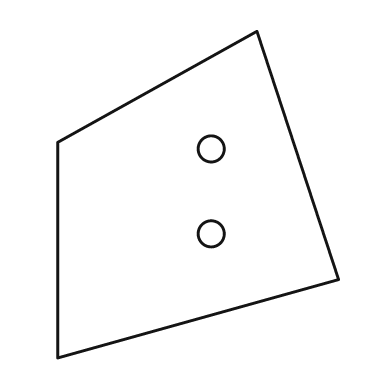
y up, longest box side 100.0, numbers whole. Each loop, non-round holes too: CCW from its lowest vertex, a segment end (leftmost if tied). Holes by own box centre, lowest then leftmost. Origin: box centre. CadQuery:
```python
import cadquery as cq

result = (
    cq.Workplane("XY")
    .moveTo(-43.0, -50.0)
    .lineTo(43.0, -26.0)
    .lineTo(18.0, 50.0)
    .lineTo(-43.0, 16.0)
    .close()
    .moveTo(4.0, -12.0)
    .circle(4.0)
    .moveTo(4.0, 14.0)
    .circle(4.0)
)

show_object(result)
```